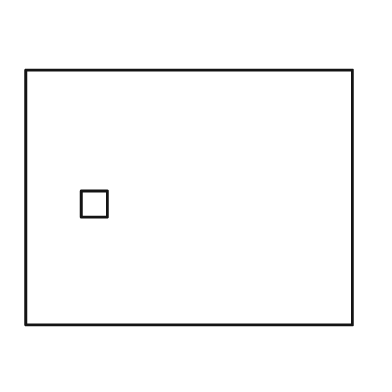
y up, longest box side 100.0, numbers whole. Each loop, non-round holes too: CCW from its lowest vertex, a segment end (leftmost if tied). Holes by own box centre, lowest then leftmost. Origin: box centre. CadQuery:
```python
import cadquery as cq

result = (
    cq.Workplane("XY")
    .moveTo(-50.0, -39.0)
    .lineTo(50.0, -39.0)
    .lineTo(50.0, 39.0)
    .lineTo(-50.0, 39.0)
    .close()
    .moveTo(-33.0, -6.0)
    .lineTo(-25.0, -6.0)
    .lineTo(-25.0, 2.0)
    .lineTo(-33.0, 2.0)
    .close()
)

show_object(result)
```